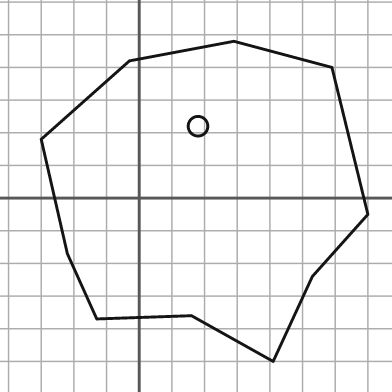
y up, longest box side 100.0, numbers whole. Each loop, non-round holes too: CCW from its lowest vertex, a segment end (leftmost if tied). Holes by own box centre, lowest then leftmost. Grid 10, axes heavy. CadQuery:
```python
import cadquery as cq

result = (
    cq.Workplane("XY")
    .moveTo(41.0, -50.0)
    .lineTo(53.0, -24.0)
    .lineTo(70.0, -5.0)
    .lineTo(59.0, 40.0)
    .lineTo(29.0, 48.0)
    .lineTo(-3.0, 42.0)
    .lineTo(-30.0, 18.0)
    .lineTo(-22.0, -17.0)
    .lineTo(-13.0, -37.0)
    .lineTo(16.0, -36.0)
    .close()
    .moveTo(18.0, 22.0)
    .circle(3.0)
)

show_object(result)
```